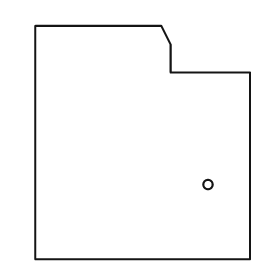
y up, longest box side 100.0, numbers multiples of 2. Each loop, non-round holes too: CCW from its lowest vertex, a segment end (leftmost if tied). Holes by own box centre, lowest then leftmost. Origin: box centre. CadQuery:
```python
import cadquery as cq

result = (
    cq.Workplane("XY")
    .moveTo(-46.0, -50.0)
    .lineTo(46.0, -50.0)
    .lineTo(46.0, 30.0)
    .lineTo(12.0, 30.0)
    .lineTo(12.0, 42.0)
    .lineTo(8.0, 50.0)
    .lineTo(-46.0, 50.0)
    .close()
    .moveTo(28.0, -18.0)
    .circle(2.0)
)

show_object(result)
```